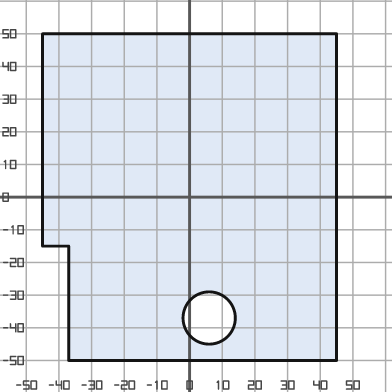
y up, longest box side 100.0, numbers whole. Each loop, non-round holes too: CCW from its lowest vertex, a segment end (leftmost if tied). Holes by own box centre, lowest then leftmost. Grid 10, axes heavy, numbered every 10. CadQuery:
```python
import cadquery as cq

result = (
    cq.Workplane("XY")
    .moveTo(-37.0, -50.0)
    .lineTo(45.0, -50.0)
    .lineTo(45.0, 50.0)
    .lineTo(-45.0, 50.0)
    .lineTo(-45.0, -15.0)
    .lineTo(-37.0, -15.0)
    .close()
    .moveTo(6.0, -37.0)
    .circle(8.0)
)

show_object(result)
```